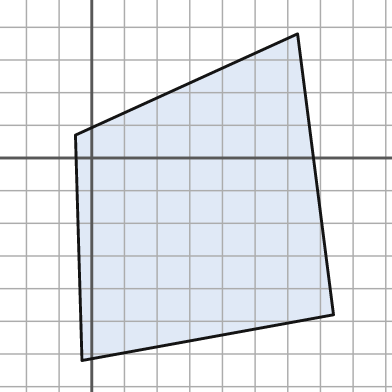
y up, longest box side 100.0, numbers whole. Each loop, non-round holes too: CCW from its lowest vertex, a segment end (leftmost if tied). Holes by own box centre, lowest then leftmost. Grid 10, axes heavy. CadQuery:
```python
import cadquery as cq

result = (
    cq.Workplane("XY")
    .moveTo(-3.0, -62.0)
    .lineTo(74.0, -48.0)
    .lineTo(63.0, 38.0)
    .lineTo(-5.0, 7.0)
    .close()
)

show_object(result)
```